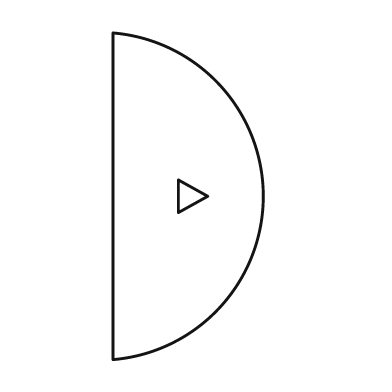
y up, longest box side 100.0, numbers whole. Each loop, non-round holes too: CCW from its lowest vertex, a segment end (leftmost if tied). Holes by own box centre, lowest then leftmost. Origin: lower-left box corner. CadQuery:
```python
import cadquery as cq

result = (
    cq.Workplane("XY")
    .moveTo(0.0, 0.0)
    .threePointArc((46.0, 50.0), (0.0, 100.0))
    .close()
    .moveTo(20.0, 45.0)
    .lineTo(29.0, 50.0)
    .lineTo(20.0, 55.0)
    .close()
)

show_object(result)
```